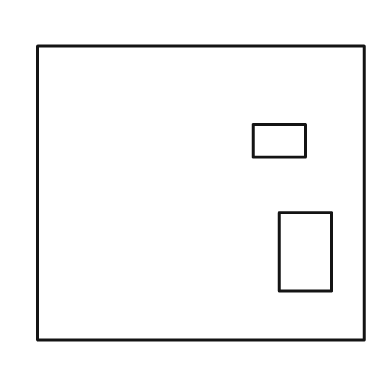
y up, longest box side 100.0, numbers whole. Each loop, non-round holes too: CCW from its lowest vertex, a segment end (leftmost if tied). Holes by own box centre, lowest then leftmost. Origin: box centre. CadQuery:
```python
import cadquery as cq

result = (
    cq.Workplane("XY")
    .moveTo(-50.0, -45.0)
    .lineTo(50.0, -45.0)
    .lineTo(50.0, 45.0)
    .lineTo(-50.0, 45.0)
    .close()
    .moveTo(24.0, -30.0)
    .lineTo(40.0, -30.0)
    .lineTo(40.0, -6.0)
    .lineTo(24.0, -6.0)
    .close()
    .moveTo(16.0, 11.0)
    .lineTo(32.0, 11.0)
    .lineTo(32.0, 21.0)
    .lineTo(16.0, 21.0)
    .close()
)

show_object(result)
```